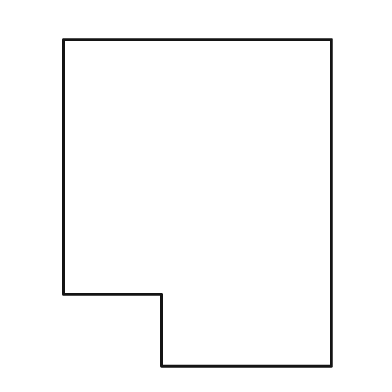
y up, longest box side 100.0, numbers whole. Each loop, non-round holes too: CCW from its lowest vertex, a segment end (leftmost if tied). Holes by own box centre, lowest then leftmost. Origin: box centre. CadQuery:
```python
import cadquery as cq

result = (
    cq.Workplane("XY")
    .moveTo(-11.0, -50.0)
    .lineTo(41.0, -50.0)
    .lineTo(41.0, 50.0)
    .lineTo(-41.0, 50.0)
    .lineTo(-41.0, -28.0)
    .lineTo(-11.0, -28.0)
    .close()
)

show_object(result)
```